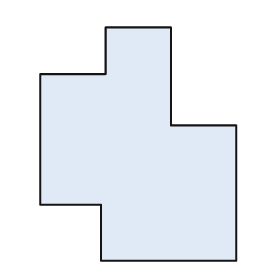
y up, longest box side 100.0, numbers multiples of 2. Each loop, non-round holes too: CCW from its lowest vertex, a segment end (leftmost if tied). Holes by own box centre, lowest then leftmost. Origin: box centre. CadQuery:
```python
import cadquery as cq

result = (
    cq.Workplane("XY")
    .moveTo(-16.0, -50.0)
    .lineTo(42.0, -50.0)
    .lineTo(42.0, 8.0)
    .lineTo(14.0, 8.0)
    .lineTo(14.0, 50.0)
    .lineTo(-14.0, 50.0)
    .lineTo(-14.0, 30.0)
    .lineTo(-42.0, 30.0)
    .lineTo(-42.0, -26.0)
    .lineTo(-16.0, -26.0)
    .close()
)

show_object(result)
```